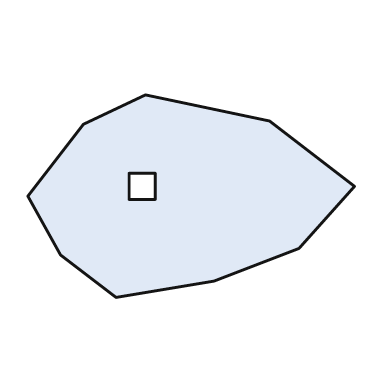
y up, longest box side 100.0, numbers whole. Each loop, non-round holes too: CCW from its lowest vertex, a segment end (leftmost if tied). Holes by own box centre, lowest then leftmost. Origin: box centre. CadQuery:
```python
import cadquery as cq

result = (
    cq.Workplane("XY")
    .moveTo(-23.0, -31.0)
    .lineTo(7.0, -26.0)
    .lineTo(33.0, -16.0)
    .lineTo(50.0, 3.0)
    .lineTo(24.0, 23.0)
    .lineTo(-14.0, 31.0)
    .lineTo(-33.0, 22.0)
    .lineTo(-50.0, 0.0)
    .lineTo(-40.0, -18.0)
    .close()
    .moveTo(-19.0, -1.0)
    .lineTo(-11.0, -1.0)
    .lineTo(-11.0, 7.0)
    .lineTo(-19.0, 7.0)
    .close()
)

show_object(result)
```